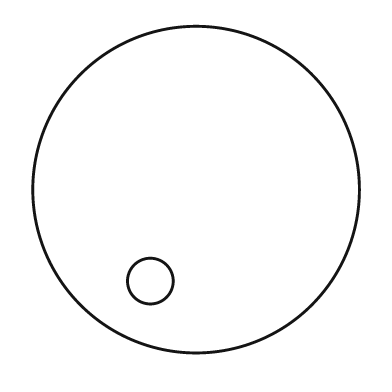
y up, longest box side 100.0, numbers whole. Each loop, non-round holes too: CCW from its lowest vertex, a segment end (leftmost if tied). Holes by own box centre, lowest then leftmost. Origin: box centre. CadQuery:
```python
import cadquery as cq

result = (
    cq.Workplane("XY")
    .moveTo(0.0, 0.0)
    .circle(50.0)
    .moveTo(-14.0, -28.0)
    .circle(7.0)
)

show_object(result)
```